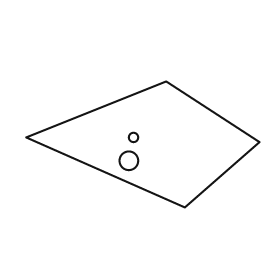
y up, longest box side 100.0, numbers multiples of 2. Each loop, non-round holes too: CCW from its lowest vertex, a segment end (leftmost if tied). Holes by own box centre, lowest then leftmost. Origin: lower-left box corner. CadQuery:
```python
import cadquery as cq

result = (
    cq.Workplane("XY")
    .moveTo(68.0, 0.0)
    .lineTo(100.0, 28.0)
    .lineTo(60.0, 54.0)
    .lineTo(0.0, 30.0)
    .close()
    .moveTo(44.0, 20.0)
    .circle(4.0)
    .moveTo(46.0, 30.0)
    .circle(2.0)
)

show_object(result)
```